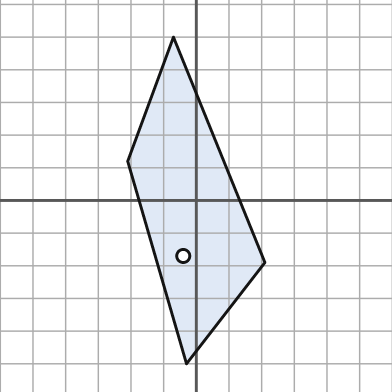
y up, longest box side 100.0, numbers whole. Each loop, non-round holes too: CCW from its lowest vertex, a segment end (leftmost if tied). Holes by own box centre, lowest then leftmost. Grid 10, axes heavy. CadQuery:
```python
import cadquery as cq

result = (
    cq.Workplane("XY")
    .moveTo(-3.0, -50.0)
    .lineTo(21.0, -19.0)
    .lineTo(-7.0, 50.0)
    .lineTo(-21.0, 12.0)
    .close()
    .moveTo(-4.0, -17.0)
    .circle(2.0)
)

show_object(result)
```